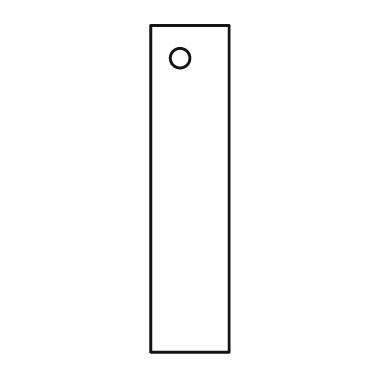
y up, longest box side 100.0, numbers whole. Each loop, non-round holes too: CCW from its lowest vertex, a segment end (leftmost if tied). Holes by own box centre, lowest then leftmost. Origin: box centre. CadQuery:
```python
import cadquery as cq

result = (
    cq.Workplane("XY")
    .moveTo(-12.0, -50.0)
    .lineTo(12.0, -50.0)
    .lineTo(12.0, 50.0)
    .lineTo(-12.0, 50.0)
    .close()
    .moveTo(-3.0, 40.0)
    .circle(3.0)
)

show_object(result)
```